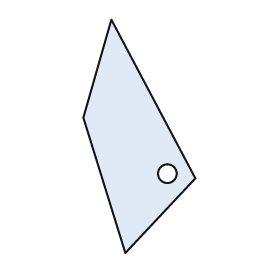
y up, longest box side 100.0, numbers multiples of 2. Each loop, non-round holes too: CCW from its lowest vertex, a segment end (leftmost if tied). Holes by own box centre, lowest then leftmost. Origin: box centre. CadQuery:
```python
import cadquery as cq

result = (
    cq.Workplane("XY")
    .moveTo(-6.0, -50.0)
    .lineTo(24.0, -18.0)
    .lineTo(-12.0, 50.0)
    .lineTo(-24.0, 8.0)
    .close()
    .moveTo(12.0, -16.0)
    .circle(4.0)
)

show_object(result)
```